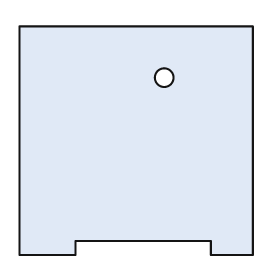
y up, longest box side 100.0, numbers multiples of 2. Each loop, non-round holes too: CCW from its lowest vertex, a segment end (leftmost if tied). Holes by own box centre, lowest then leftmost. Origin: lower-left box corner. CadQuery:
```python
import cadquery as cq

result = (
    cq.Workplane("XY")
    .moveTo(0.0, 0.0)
    .lineTo(24.0, 0.0)
    .lineTo(24.0, 6.0)
    .lineTo(82.0, 6.0)
    .lineTo(82.0, 0.0)
    .lineTo(100.0, 0.0)
    .lineTo(100.0, 98.0)
    .lineTo(0.0, 98.0)
    .close()
    .moveTo(62.0, 76.0)
    .circle(4.0)
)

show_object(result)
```